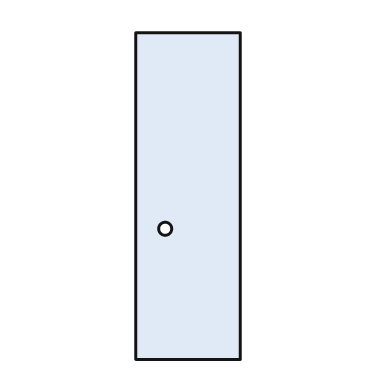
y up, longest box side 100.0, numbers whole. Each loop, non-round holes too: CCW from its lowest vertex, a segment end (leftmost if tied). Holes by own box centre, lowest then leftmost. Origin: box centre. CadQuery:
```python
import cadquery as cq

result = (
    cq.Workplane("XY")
    .moveTo(-16.0, -50.0)
    .lineTo(16.0, -50.0)
    .lineTo(16.0, 50.0)
    .lineTo(-16.0, 50.0)
    .close()
    .moveTo(-7.0, -10.0)
    .circle(2.0)
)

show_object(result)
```